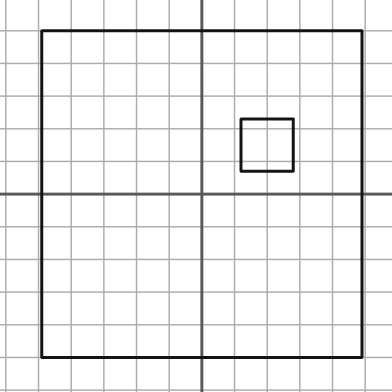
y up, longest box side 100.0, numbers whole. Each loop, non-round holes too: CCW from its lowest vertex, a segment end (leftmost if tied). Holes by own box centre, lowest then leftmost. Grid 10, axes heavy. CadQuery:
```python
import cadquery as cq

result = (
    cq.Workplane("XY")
    .moveTo(-49.0, -50.0)
    .lineTo(49.0, -50.0)
    .lineTo(49.0, 50.0)
    .lineTo(-49.0, 50.0)
    .close()
    .moveTo(12.0, 7.0)
    .lineTo(28.0, 7.0)
    .lineTo(28.0, 23.0)
    .lineTo(12.0, 23.0)
    .close()
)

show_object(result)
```